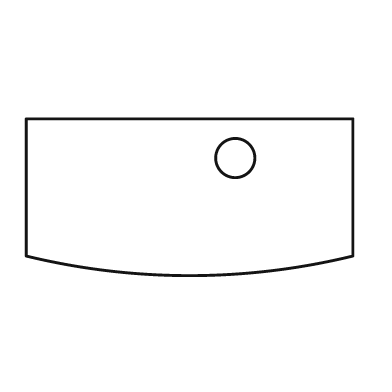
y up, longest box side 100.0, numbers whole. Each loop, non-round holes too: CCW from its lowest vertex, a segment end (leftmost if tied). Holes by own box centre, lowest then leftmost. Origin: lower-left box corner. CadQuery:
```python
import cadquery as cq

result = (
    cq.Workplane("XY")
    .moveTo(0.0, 6.0)
    .threePointArc((50.0, 0.0), (100.0, 6.0))
    .lineTo(100.0, 48.0)
    .lineTo(0.0, 48.0)
    .close()
    .moveTo(64.0, 36.0)
    .circle(6.0)
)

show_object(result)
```